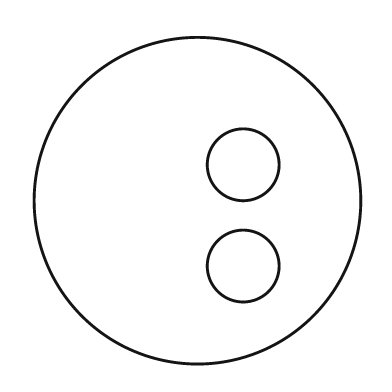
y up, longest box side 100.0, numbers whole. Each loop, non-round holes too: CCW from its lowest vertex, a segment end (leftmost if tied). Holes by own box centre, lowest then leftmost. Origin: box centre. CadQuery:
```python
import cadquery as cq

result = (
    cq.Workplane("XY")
    .moveTo(0.0, 0.0)
    .circle(50.0)
    .moveTo(14.0, -20.0)
    .circle(11.0)
    .moveTo(14.0, 11.0)
    .circle(11.0)
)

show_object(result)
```